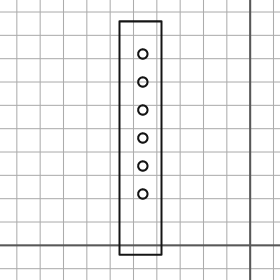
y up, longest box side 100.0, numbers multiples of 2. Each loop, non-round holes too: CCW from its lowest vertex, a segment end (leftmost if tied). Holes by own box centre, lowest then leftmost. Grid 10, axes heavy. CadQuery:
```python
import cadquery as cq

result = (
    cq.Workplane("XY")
    .moveTo(-56.0, -4.0)
    .lineTo(-38.0, -4.0)
    .lineTo(-38.0, 96.0)
    .lineTo(-56.0, 96.0)
    .close()
    .moveTo(-46.0, 22.0)
    .circle(2.0)
    .moveTo(-46.0, 34.0)
    .circle(2.0)
    .moveTo(-46.0, 46.0)
    .circle(2.0)
    .moveTo(-46.0, 58.0)
    .circle(2.0)
    .moveTo(-46.0, 70.0)
    .circle(2.0)
    .moveTo(-46.0, 82.0)
    .circle(2.0)
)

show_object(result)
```